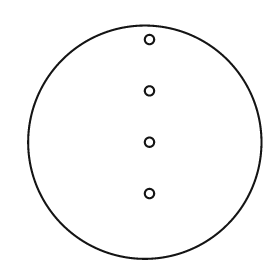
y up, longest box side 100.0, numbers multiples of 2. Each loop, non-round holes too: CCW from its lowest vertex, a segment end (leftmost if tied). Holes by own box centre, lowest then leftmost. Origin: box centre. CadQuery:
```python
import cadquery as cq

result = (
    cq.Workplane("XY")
    .moveTo(0.0, 0.0)
    .circle(50.0)
    .moveTo(2.0, -22.0)
    .circle(2.0)
    .moveTo(2.0, 0.0)
    .circle(2.0)
    .moveTo(2.0, 22.0)
    .circle(2.0)
    .moveTo(2.0, 44.0)
    .circle(2.0)
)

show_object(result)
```